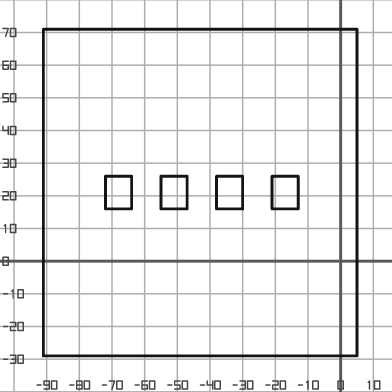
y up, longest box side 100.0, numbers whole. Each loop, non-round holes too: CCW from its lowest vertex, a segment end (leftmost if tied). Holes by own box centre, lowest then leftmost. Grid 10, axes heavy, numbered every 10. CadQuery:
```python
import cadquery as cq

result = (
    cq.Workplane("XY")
    .moveTo(-91.0, -29.0)
    .lineTo(5.0, -29.0)
    .lineTo(5.0, 71.0)
    .lineTo(-91.0, 71.0)
    .close()
    .moveTo(-72.0, 16.0)
    .lineTo(-64.0, 16.0)
    .lineTo(-64.0, 26.0)
    .lineTo(-72.0, 26.0)
    .close()
    .moveTo(-55.0, 16.0)
    .lineTo(-47.0, 16.0)
    .lineTo(-47.0, 26.0)
    .lineTo(-55.0, 26.0)
    .close()
    .moveTo(-38.0, 16.0)
    .lineTo(-30.0, 16.0)
    .lineTo(-30.0, 26.0)
    .lineTo(-38.0, 26.0)
    .close()
    .moveTo(-21.0, 16.0)
    .lineTo(-13.0, 16.0)
    .lineTo(-13.0, 26.0)
    .lineTo(-21.0, 26.0)
    .close()
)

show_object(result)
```